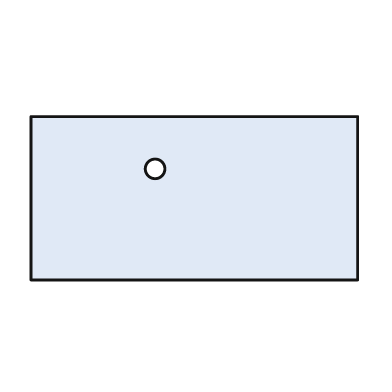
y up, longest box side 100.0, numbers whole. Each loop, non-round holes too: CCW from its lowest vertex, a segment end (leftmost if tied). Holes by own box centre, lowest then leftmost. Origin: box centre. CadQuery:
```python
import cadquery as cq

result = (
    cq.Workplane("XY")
    .moveTo(-50.0, -25.0)
    .lineTo(50.0, -25.0)
    .lineTo(50.0, 25.0)
    .lineTo(-50.0, 25.0)
    .close()
    .moveTo(-12.0, 9.0)
    .circle(3.0)
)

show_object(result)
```